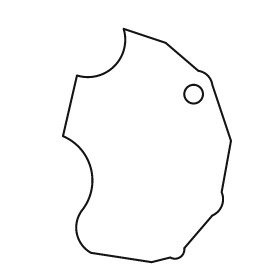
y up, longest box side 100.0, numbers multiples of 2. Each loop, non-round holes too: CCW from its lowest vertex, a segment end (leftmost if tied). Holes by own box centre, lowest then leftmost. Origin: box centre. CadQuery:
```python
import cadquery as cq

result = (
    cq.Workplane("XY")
    .moveTo(2.0, -50.0)
    .lineTo(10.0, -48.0)
    .threePointArc((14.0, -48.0), (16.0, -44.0))
    .lineTo(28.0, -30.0)
    .threePointArc((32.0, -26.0), (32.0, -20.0))
    .lineTo(36.0, 2.0)
    .lineTo(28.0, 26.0)
    .threePointArc((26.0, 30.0), (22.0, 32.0))
    .lineTo(8.0, 44.0)
    .lineTo(-10.0, 50.0)
    .threePointArc((-14.0, 34.0), (-30.0, 30.0))
    .lineTo(-36.0, 4.0)
    .threePointArc((-24.0, -10.0), (-28.0, -28.0))
    .threePointArc((-30.0, -38.0), (-24.0, -46.0))
    .close()
    .moveTo(20.0, 22.0)
    .circle(4.0)
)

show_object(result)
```